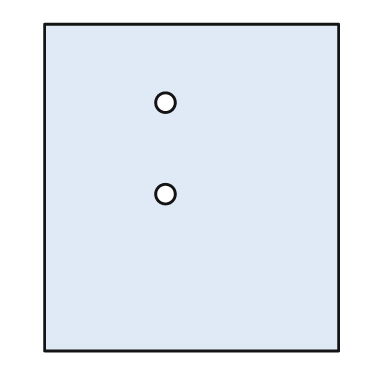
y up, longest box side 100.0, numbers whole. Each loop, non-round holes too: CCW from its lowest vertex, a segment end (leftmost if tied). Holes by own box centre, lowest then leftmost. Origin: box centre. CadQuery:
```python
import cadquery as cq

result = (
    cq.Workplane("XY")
    .moveTo(-45.0, -50.0)
    .lineTo(45.0, -50.0)
    .lineTo(45.0, 50.0)
    .lineTo(-45.0, 50.0)
    .close()
    .moveTo(-8.0, -2.0)
    .circle(3.0)
    .moveTo(-8.0, 26.0)
    .circle(3.0)
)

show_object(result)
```